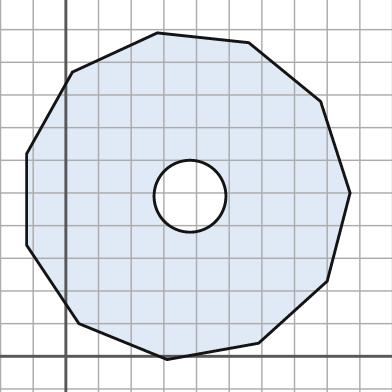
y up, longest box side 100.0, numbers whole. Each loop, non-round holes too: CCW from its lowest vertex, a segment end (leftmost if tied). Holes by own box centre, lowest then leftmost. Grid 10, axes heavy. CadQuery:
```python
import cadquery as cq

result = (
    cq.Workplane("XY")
    .moveTo(31.0, -1.0)
    .lineTo(59.0, 4.0)
    .lineTo(80.0, 23.0)
    .lineTo(87.0, 50.0)
    .lineTo(78.0, 78.0)
    .lineTo(56.0, 96.0)
    .lineTo(28.0, 99.0)
    .lineTo(2.0, 87.0)
    .lineTo(-12.0, 62.0)
    .lineTo(-12.0, 34.0)
    .lineTo(4.0, 10.0)
    .close()
    .moveTo(38.0, 49.0)
    .circle(11.0)
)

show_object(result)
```